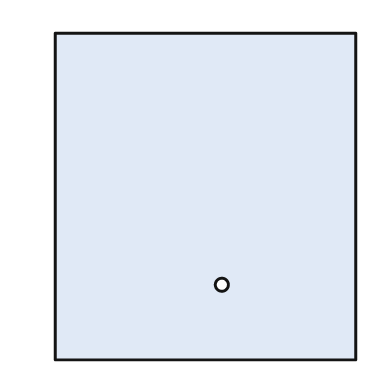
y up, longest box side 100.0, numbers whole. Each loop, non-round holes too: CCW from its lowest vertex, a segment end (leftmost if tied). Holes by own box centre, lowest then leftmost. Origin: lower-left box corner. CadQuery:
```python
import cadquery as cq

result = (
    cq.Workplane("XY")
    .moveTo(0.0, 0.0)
    .lineTo(92.0, 0.0)
    .lineTo(92.0, 100.0)
    .lineTo(0.0, 100.0)
    .close()
    .moveTo(51.0, 23.0)
    .circle(2.0)
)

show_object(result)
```